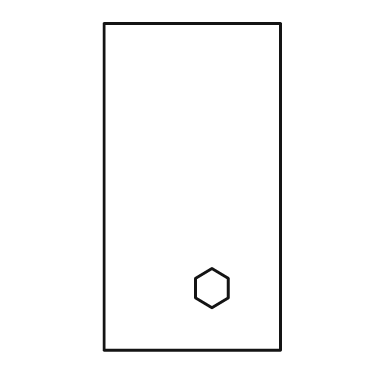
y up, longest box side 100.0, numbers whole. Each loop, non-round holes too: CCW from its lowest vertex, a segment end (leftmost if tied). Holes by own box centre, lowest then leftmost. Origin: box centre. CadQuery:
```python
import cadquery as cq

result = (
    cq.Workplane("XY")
    .moveTo(-27.0, -50.0)
    .lineTo(27.0, -50.0)
    .lineTo(27.0, 50.0)
    .lineTo(-27.0, 50.0)
    .close()
    .moveTo(6.0, -37.0)
    .lineTo(11.0, -34.0)
    .lineTo(11.0, -28.0)
    .lineTo(6.0, -25.0)
    .lineTo(1.0, -28.0)
    .lineTo(1.0, -34.0)
    .close()
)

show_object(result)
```